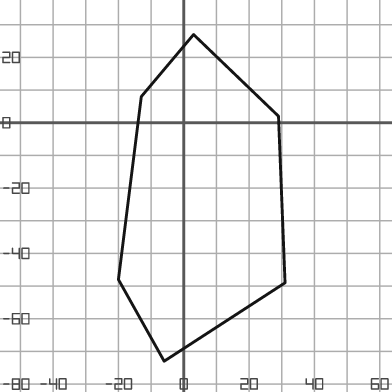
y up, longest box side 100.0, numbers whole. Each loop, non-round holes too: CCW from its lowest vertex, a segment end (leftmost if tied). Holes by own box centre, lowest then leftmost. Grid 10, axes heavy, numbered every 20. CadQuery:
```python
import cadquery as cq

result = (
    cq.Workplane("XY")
    .moveTo(-6.0, -73.0)
    .lineTo(31.0, -49.0)
    .lineTo(29.0, 2.0)
    .lineTo(3.0, 27.0)
    .lineTo(-13.0, 8.0)
    .lineTo(-20.0, -48.0)
    .close()
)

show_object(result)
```